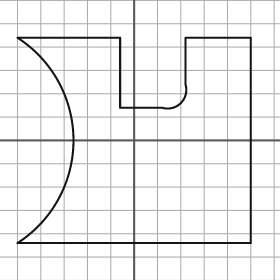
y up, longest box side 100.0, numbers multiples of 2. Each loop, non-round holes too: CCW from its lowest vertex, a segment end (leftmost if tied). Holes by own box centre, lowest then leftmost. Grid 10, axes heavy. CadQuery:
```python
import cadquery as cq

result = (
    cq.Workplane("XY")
    .moveTo(-50.0, -44.0)
    .lineTo(50.0, -44.0)
    .lineTo(50.0, 44.0)
    .lineTo(22.0, 44.0)
    .lineTo(22.0, 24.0)
    .threePointArc((20.0, 16.0), (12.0, 14.0))
    .lineTo(-6.0, 14.0)
    .lineTo(-6.0, 44.0)
    .lineTo(-50.0, 44.0)
    .threePointArc((-26.0, 0.0), (-50.0, -44.0))
    .close()
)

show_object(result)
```